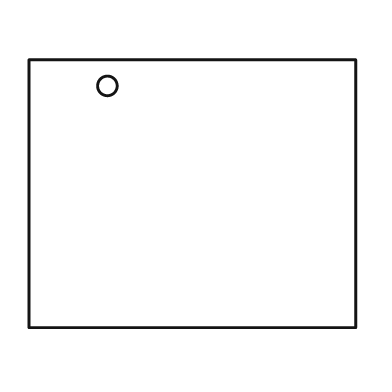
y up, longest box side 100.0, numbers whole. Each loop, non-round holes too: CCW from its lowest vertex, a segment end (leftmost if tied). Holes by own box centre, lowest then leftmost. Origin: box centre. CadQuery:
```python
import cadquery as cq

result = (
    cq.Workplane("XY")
    .moveTo(-50.0, -41.0)
    .lineTo(50.0, -41.0)
    .lineTo(50.0, 41.0)
    .lineTo(-50.0, 41.0)
    .close()
    .moveTo(-26.0, 33.0)
    .circle(3.0)
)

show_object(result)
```